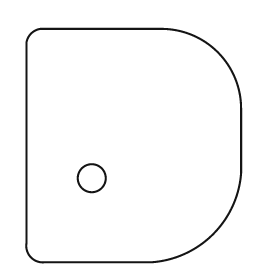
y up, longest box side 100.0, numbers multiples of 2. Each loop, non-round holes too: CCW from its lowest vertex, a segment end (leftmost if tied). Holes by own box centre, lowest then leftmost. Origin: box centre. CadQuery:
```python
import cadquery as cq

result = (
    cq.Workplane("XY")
    .moveTo(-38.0, -50.0)
    .lineTo(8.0, -50.0)
    .threePointArc((34.0, -38.0), (46.0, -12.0))
    .lineTo(46.0, 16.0)
    .threePointArc((36.0, 40.0), (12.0, 50.0))
    .lineTo(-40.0, 50.0)
    .threePointArc((-44.0, 48.0), (-46.0, 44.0))
    .lineTo(-46.0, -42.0)
    .threePointArc((-44.0, -48.0), (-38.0, -50.0))
    .close()
    .moveTo(-18.0, -14.0)
    .circle(6.0)
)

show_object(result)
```